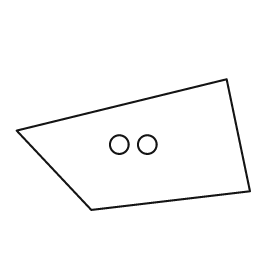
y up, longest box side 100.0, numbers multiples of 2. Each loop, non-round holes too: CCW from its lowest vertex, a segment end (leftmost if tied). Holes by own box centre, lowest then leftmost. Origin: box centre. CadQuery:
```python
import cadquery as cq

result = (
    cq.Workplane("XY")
    .moveTo(-18.0, -28.0)
    .lineTo(50.0, -20.0)
    .lineTo(40.0, 28.0)
    .lineTo(-50.0, 6.0)
    .close()
    .moveTo(-6.0, 0.0)
    .circle(4.0)
    .moveTo(6.0, 0.0)
    .circle(4.0)
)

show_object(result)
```